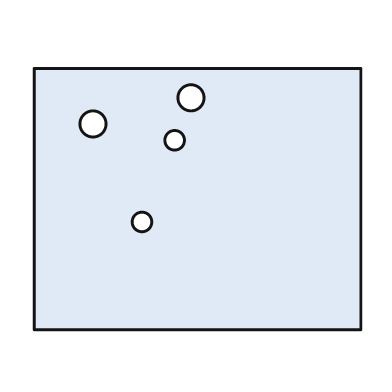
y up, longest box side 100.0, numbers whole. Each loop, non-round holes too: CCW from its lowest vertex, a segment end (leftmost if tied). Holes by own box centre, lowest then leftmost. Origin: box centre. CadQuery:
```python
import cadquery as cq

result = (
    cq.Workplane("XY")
    .moveTo(-50.0, -40.0)
    .lineTo(50.0, -40.0)
    .lineTo(50.0, 40.0)
    .lineTo(-50.0, 40.0)
    .close()
    .moveTo(-17.0, -7.0)
    .circle(3.0)
    .moveTo(-7.0, 18.0)
    .circle(3.0)
    .moveTo(-32.0, 23.0)
    .circle(4.0)
    .moveTo(-2.0, 31.0)
    .circle(4.0)
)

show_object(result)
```